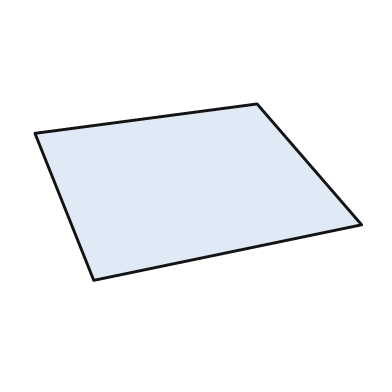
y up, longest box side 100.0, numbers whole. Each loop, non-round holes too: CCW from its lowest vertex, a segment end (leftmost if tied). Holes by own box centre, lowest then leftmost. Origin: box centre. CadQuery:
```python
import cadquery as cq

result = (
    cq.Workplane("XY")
    .moveTo(-32.0, -27.0)
    .lineTo(50.0, -10.0)
    .lineTo(18.0, 27.0)
    .lineTo(-50.0, 18.0)
    .close()
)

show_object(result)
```